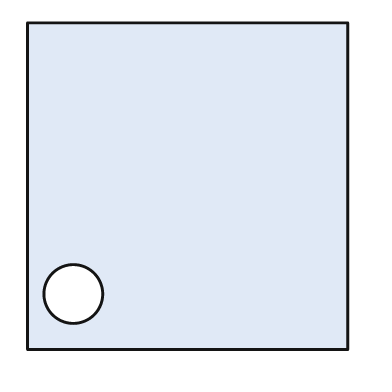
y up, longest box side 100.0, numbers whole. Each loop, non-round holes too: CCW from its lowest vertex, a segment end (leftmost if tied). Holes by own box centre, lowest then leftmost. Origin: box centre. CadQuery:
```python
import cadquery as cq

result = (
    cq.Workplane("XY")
    .moveTo(-49.0, -50.0)
    .lineTo(49.0, -50.0)
    .lineTo(49.0, 50.0)
    .lineTo(-49.0, 50.0)
    .close()
    .moveTo(-35.0, -33.0)
    .circle(9.0)
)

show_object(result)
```